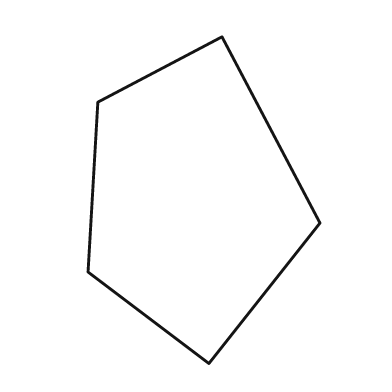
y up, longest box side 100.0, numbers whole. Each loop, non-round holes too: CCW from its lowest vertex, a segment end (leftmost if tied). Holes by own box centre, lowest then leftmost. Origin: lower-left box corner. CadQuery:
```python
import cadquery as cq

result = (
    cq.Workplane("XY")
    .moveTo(37.0, 0.0)
    .lineTo(71.0, 43.0)
    .lineTo(41.0, 100.0)
    .lineTo(3.0, 80.0)
    .lineTo(0.0, 28.0)
    .close()
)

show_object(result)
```